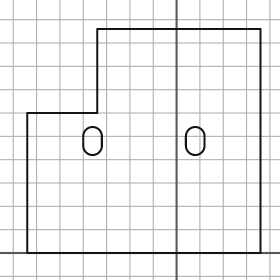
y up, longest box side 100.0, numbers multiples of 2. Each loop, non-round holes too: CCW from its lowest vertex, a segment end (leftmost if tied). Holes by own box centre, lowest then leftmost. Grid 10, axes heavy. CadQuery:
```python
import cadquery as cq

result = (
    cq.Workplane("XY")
    .moveTo(-64.0, 0.0)
    .lineTo(36.0, 0.0)
    .lineTo(36.0, 96.0)
    .lineTo(-34.0, 96.0)
    .lineTo(-34.0, 60.0)
    .lineTo(-64.0, 60.0)
    .close()
    .moveTo(-40.0, 46.0)
    .threePointArc((-36.0, 42.0), (-32.0, 46.0))
    .lineTo(-32.0, 50.0)
    .threePointArc((-36.0, 54.0), (-40.0, 50.0))
    .close()
    .moveTo(4.0, 46.0)
    .threePointArc((8.0, 42.0), (12.0, 46.0))
    .lineTo(12.0, 50.0)
    .threePointArc((8.0, 54.0), (4.0, 50.0))
    .close()
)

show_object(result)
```